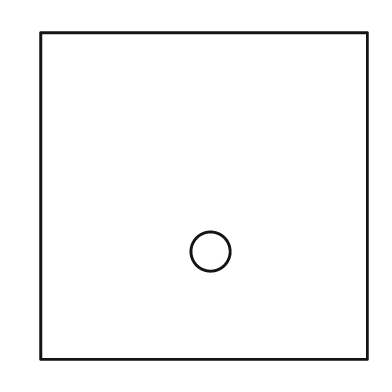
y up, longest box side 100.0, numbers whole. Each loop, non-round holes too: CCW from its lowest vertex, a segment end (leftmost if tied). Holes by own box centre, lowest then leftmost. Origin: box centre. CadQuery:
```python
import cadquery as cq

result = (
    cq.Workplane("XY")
    .moveTo(-50.0, -50.0)
    .lineTo(50.0, -50.0)
    .lineTo(50.0, 50.0)
    .lineTo(-50.0, 50.0)
    .close()
    .moveTo(2.0, -17.0)
    .circle(6.0)
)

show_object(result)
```